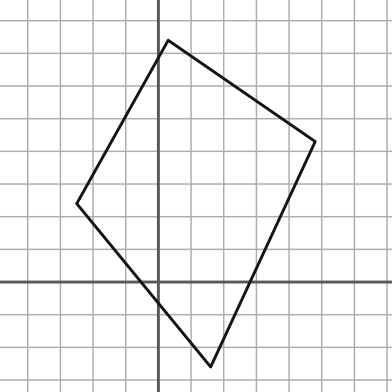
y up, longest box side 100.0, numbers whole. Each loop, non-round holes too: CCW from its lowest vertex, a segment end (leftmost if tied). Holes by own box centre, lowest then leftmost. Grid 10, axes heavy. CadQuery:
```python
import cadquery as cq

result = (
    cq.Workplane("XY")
    .moveTo(16.0, -26.0)
    .lineTo(48.0, 43.0)
    .lineTo(3.0, 74.0)
    .lineTo(-25.0, 24.0)
    .close()
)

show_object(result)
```